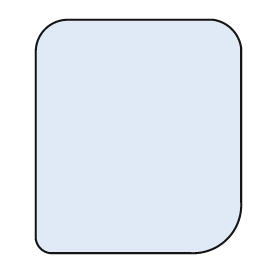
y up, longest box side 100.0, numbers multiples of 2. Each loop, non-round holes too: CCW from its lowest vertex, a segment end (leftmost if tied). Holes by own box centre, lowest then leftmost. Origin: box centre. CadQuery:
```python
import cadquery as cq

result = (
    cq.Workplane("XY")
    .moveTo(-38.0, -50.0)
    .lineTo(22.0, -50.0)
    .threePointArc((38.0, -44.0), (44.0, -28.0))
    .lineTo(44.0, 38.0)
    .threePointArc((40.0, 46.0), (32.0, 50.0))
    .lineTo(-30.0, 50.0)
    .threePointArc((-40.0, 46.0), (-44.0, 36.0))
    .lineTo(-44.0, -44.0)
    .threePointArc((-42.0, -48.0), (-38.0, -50.0))
    .close()
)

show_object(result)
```